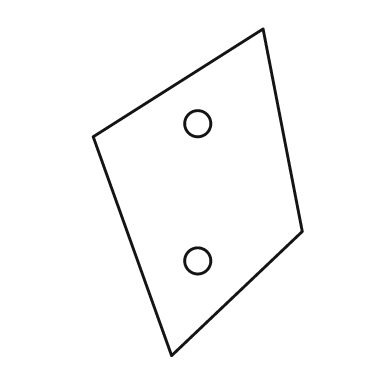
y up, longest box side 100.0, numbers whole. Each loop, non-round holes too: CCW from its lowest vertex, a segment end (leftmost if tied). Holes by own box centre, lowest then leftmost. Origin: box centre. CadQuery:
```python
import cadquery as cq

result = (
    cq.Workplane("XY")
    .moveTo(-8.0, -50.0)
    .lineTo(32.0, -12.0)
    .lineTo(20.0, 50.0)
    .lineTo(-32.0, 17.0)
    .close()
    .moveTo(0.0, -21.0)
    .circle(4.0)
    .moveTo(0.0, 21.0)
    .circle(4.0)
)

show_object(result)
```